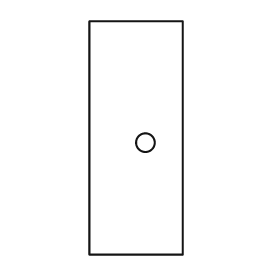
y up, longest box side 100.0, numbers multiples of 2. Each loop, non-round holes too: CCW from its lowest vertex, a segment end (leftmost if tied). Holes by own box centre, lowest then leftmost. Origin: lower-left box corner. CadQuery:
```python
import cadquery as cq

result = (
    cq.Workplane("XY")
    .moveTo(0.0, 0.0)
    .lineTo(40.0, 0.0)
    .lineTo(40.0, 100.0)
    .lineTo(0.0, 100.0)
    .close()
    .moveTo(24.0, 48.0)
    .circle(4.0)
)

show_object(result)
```